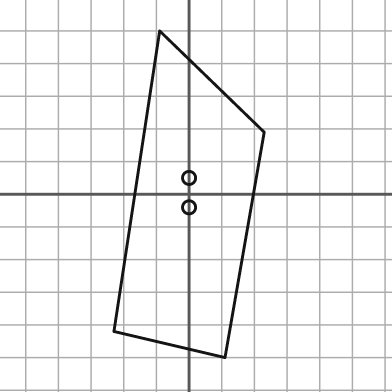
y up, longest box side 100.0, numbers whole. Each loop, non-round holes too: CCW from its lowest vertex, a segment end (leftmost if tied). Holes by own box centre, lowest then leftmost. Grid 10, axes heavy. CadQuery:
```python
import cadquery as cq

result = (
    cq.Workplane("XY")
    .moveTo(11.0, -50.0)
    .lineTo(23.0, 19.0)
    .lineTo(-9.0, 50.0)
    .lineTo(-23.0, -42.0)
    .close()
    .moveTo(0.0, -4.0)
    .circle(2.0)
    .moveTo(0.0, 5.0)
    .circle(2.0)
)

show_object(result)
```